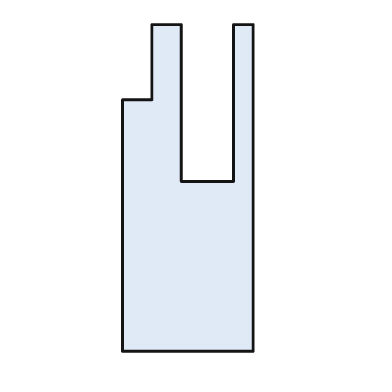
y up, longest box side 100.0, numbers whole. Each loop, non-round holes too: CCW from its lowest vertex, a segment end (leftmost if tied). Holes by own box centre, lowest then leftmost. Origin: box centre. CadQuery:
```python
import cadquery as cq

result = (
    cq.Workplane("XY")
    .moveTo(-20.0, -50.0)
    .lineTo(20.0, -50.0)
    .lineTo(20.0, 50.0)
    .lineTo(14.0, 50.0)
    .lineTo(14.0, 2.0)
    .lineTo(-2.0, 2.0)
    .lineTo(-2.0, 50.0)
    .lineTo(-11.0, 50.0)
    .lineTo(-11.0, 27.0)
    .lineTo(-20.0, 27.0)
    .close()
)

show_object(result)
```